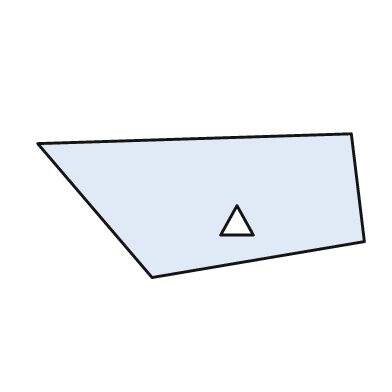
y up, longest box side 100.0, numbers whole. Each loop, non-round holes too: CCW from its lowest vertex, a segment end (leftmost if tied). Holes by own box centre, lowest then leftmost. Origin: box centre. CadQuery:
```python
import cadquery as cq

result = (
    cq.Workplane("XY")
    .moveTo(-15.0, -22.0)
    .lineTo(50.0, -11.0)
    .lineTo(46.0, 22.0)
    .lineTo(-50.0, 19.0)
    .close()
    .moveTo(6.0, -9.0)
    .lineTo(16.0, -9.0)
    .lineTo(11.0, 0.0)
    .close()
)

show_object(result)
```